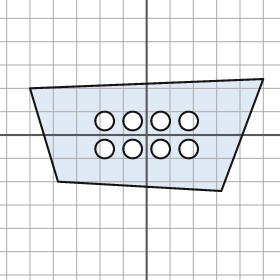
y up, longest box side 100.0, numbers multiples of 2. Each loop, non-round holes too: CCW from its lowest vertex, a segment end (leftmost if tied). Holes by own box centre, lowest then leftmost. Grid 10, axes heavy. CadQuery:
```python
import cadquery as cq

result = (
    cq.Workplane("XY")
    .moveTo(32.0, -24.0)
    .lineTo(50.0, 24.0)
    .lineTo(-50.0, 20.0)
    .lineTo(-38.0, -20.0)
    .close()
    .moveTo(-18.0, -6.0)
    .circle(4.0)
    .moveTo(-6.0, -6.0)
    .circle(4.0)
    .moveTo(6.0, -6.0)
    .circle(4.0)
    .moveTo(18.0, -6.0)
    .circle(4.0)
    .moveTo(-18.0, 6.0)
    .circle(4.0)
    .moveTo(-6.0, 6.0)
    .circle(4.0)
    .moveTo(6.0, 6.0)
    .circle(4.0)
    .moveTo(18.0, 6.0)
    .circle(4.0)
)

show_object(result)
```